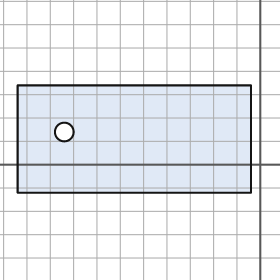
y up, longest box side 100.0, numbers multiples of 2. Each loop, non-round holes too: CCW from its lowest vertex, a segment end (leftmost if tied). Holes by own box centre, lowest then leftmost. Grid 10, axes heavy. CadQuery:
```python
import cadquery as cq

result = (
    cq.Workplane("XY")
    .moveTo(-104.0, -12.0)
    .lineTo(-4.0, -12.0)
    .lineTo(-4.0, 34.0)
    .lineTo(-104.0, 34.0)
    .close()
    .moveTo(-84.0, 14.0)
    .circle(4.0)
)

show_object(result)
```